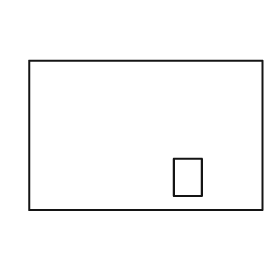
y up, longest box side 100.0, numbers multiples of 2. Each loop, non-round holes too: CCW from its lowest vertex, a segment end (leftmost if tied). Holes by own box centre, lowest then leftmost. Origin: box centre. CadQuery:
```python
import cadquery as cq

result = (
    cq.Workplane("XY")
    .moveTo(-50.0, -32.0)
    .lineTo(50.0, -32.0)
    .lineTo(50.0, 32.0)
    .lineTo(-50.0, 32.0)
    .close()
    .moveTo(12.0, -26.0)
    .lineTo(24.0, -26.0)
    .lineTo(24.0, -10.0)
    .lineTo(12.0, -10.0)
    .close()
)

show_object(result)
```